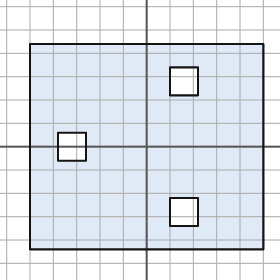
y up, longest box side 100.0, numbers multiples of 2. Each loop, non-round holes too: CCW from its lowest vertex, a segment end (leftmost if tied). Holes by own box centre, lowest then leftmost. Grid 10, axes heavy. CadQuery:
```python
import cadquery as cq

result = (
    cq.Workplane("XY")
    .moveTo(-50.0, -44.0)
    .lineTo(50.0, -44.0)
    .lineTo(50.0, 44.0)
    .lineTo(-50.0, 44.0)
    .close()
    .moveTo(10.0, -34.0)
    .lineTo(22.0, -34.0)
    .lineTo(22.0, -22.0)
    .lineTo(10.0, -22.0)
    .close()
    .moveTo(-38.0, -6.0)
    .lineTo(-26.0, -6.0)
    .lineTo(-26.0, 6.0)
    .lineTo(-38.0, 6.0)
    .close()
    .moveTo(10.0, 22.0)
    .lineTo(22.0, 22.0)
    .lineTo(22.0, 34.0)
    .lineTo(10.0, 34.0)
    .close()
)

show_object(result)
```